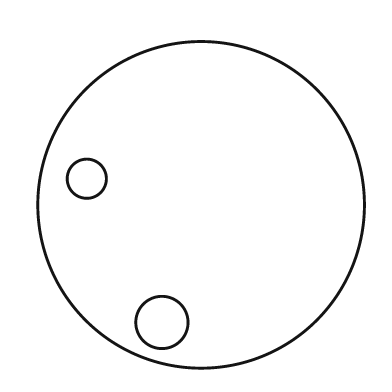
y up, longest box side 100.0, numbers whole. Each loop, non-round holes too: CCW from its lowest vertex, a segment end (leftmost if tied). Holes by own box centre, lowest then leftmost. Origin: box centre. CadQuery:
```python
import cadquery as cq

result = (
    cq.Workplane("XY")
    .moveTo(0.0, 0.0)
    .circle(50.0)
    .moveTo(-12.0, -36.0)
    .circle(8.0)
    .moveTo(-35.0, 8.0)
    .circle(6.0)
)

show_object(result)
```